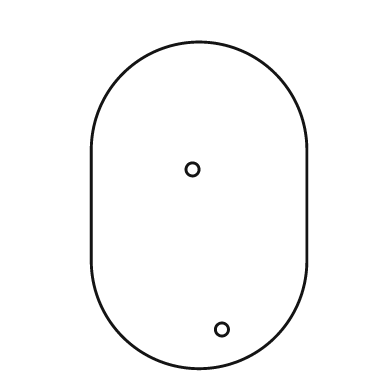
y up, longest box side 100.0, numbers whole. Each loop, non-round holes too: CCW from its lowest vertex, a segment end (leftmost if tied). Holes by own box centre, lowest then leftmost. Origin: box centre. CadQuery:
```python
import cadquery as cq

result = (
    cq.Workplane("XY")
    .moveTo(-33.0, -17.0)
    .threePointArc((0.0, -50.0), (33.0, -17.0))
    .lineTo(33.0, 17.0)
    .threePointArc((0.0, 50.0), (-33.0, 17.0))
    .close()
    .moveTo(7.0, -38.0)
    .circle(2.0)
    .moveTo(-2.0, 11.0)
    .circle(2.0)
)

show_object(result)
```